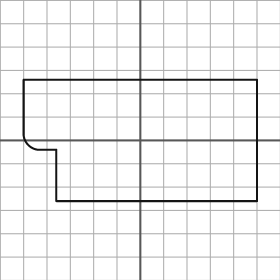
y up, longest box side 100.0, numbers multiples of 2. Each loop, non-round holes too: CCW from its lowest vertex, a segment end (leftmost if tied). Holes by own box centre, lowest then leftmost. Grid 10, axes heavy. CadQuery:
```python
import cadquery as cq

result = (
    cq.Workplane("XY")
    .moveTo(-36.0, -26.0)
    .lineTo(50.0, -26.0)
    .lineTo(50.0, 26.0)
    .lineTo(-50.0, 26.0)
    .lineTo(-50.0, 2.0)
    .threePointArc((-48.0, -2.0), (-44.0, -4.0))
    .lineTo(-36.0, -4.0)
    .close()
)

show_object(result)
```